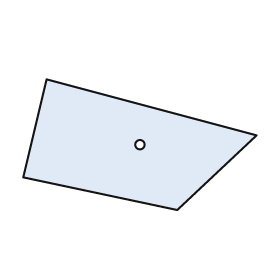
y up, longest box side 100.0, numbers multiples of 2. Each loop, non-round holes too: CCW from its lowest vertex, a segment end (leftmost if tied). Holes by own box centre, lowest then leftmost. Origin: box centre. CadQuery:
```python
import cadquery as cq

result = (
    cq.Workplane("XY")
    .moveTo(16.0, -28.0)
    .lineTo(50.0, 4.0)
    .lineTo(-40.0, 28.0)
    .lineTo(-50.0, -14.0)
    .close()
    .moveTo(0.0, 0.0)
    .circle(2.0)
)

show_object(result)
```